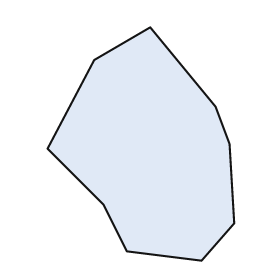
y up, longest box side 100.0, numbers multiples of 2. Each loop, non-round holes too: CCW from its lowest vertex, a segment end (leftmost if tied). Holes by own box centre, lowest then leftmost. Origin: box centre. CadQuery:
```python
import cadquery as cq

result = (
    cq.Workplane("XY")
    .moveTo(26.0, -50.0)
    .lineTo(40.0, -34.0)
    .lineTo(38.0, 0.0)
    .lineTo(32.0, 16.0)
    .lineTo(4.0, 50.0)
    .lineTo(-20.0, 36.0)
    .lineTo(-40.0, -2.0)
    .lineTo(-16.0, -26.0)
    .lineTo(-6.0, -46.0)
    .close()
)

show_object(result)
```